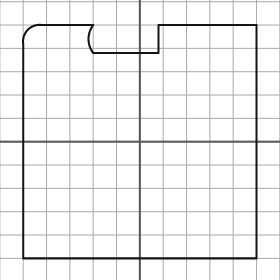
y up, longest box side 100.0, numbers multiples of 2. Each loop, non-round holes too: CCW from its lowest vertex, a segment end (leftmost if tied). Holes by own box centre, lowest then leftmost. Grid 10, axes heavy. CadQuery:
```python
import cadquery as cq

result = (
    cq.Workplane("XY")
    .moveTo(-50.0, -50.0)
    .lineTo(50.0, -50.0)
    .lineTo(50.0, 50.0)
    .lineTo(8.0, 50.0)
    .lineTo(8.0, 38.0)
    .lineTo(-20.0, 38.0)
    .threePointArc((-22.0, 44.0), (-20.0, 50.0))
    .lineTo(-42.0, 50.0)
    .threePointArc((-48.0, 48.0), (-50.0, 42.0))
    .close()
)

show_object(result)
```